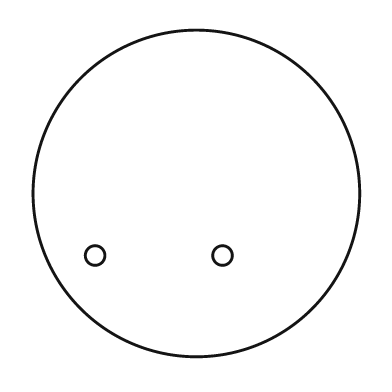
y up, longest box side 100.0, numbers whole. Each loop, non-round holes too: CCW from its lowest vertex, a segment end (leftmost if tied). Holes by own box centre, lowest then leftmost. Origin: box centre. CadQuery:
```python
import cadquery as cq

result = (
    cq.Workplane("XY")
    .moveTo(0.0, 0.0)
    .circle(50.0)
    .moveTo(-31.0, -19.0)
    .circle(3.0)
    .moveTo(8.0, -19.0)
    .circle(3.0)
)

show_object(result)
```